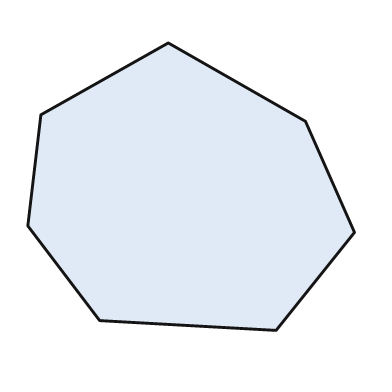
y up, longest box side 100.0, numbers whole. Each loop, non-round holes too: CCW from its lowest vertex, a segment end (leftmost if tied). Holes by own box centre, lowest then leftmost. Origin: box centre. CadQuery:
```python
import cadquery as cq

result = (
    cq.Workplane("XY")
    .moveTo(26.0, -44.0)
    .lineTo(50.0, -14.0)
    .lineTo(35.0, 20.0)
    .lineTo(-7.0, 44.0)
    .lineTo(-46.0, 22.0)
    .lineTo(-50.0, -12.0)
    .lineTo(-28.0, -41.0)
    .close()
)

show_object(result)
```